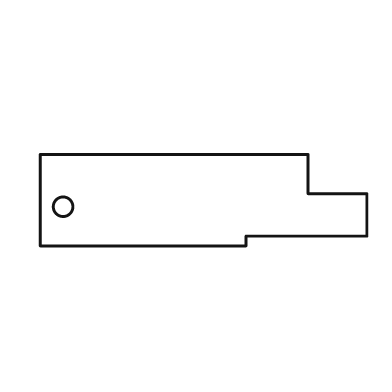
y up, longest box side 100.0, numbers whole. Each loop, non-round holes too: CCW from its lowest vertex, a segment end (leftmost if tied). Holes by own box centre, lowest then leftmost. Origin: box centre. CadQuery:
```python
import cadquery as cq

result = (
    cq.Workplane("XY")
    .moveTo(-50.0, -14.0)
    .lineTo(13.0, -14.0)
    .lineTo(13.0, -11.0)
    .lineTo(50.0, -11.0)
    .lineTo(50.0, 2.0)
    .lineTo(32.0, 2.0)
    .lineTo(32.0, 14.0)
    .lineTo(-50.0, 14.0)
    .close()
    .moveTo(-43.0, -2.0)
    .circle(3.0)
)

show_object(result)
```